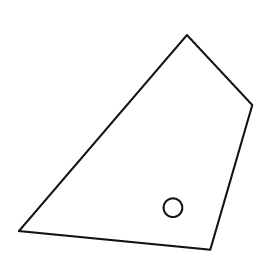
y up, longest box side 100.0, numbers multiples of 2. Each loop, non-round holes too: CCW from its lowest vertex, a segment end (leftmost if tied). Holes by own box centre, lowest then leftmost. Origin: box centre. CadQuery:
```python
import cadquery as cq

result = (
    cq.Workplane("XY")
    .moveTo(32.0, -46.0)
    .lineTo(50.0, 16.0)
    .lineTo(22.0, 46.0)
    .lineTo(-50.0, -38.0)
    .close()
    .moveTo(16.0, -28.0)
    .circle(4.0)
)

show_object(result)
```